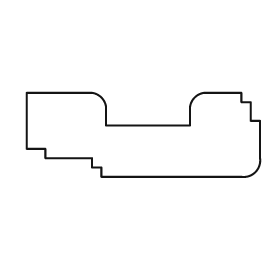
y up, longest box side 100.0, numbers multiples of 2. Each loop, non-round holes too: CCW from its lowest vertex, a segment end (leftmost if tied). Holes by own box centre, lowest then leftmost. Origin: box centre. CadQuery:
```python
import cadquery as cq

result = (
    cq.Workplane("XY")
    .moveTo(-18.0, -18.0)
    .lineTo(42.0, -18.0)
    .threePointArc((48.0, -16.0), (50.0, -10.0))
    .lineTo(50.0, 6.0)
    .lineTo(46.0, 6.0)
    .lineTo(46.0, 14.0)
    .lineTo(42.0, 14.0)
    .lineTo(42.0, 18.0)
    .lineTo(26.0, 18.0)
    .threePointArc((22.0, 16.0), (20.0, 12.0))
    .lineTo(20.0, 4.0)
    .lineTo(-16.0, 4.0)
    .lineTo(-16.0, 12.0)
    .threePointArc((-18.0, 16.0), (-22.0, 18.0))
    .lineTo(-50.0, 18.0)
    .lineTo(-50.0, -6.0)
    .lineTo(-42.0, -6.0)
    .lineTo(-42.0, -10.0)
    .lineTo(-22.0, -10.0)
    .lineTo(-22.0, -14.0)
    .lineTo(-18.0, -14.0)
    .close()
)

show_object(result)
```